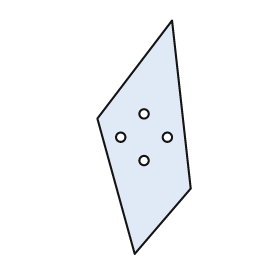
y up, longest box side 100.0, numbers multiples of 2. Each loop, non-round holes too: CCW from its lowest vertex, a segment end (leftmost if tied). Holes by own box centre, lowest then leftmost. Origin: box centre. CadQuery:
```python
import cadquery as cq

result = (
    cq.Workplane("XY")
    .moveTo(-4.0, -50.0)
    .lineTo(20.0, -22.0)
    .lineTo(12.0, 50.0)
    .lineTo(-20.0, 8.0)
    .close()
    .moveTo(0.0, -10.0)
    .circle(2.0)
    .moveTo(-10.0, 0.0)
    .circle(2.0)
    .moveTo(10.0, 0.0)
    .circle(2.0)
    .moveTo(0.0, 10.0)
    .circle(2.0)
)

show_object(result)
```